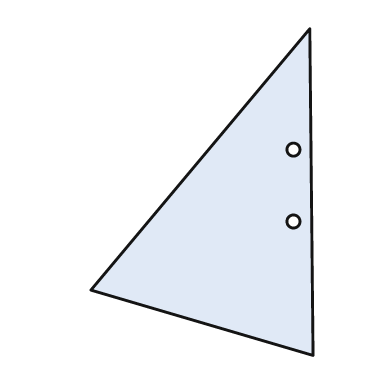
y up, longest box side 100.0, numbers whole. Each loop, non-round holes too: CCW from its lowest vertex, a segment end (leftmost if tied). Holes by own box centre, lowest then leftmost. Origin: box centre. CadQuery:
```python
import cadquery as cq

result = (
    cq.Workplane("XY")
    .moveTo(34.0, -50.0)
    .lineTo(33.0, 50.0)
    .lineTo(-34.0, -30.0)
    .close()
    .moveTo(28.0, -9.0)
    .circle(2.0)
    .moveTo(28.0, 13.0)
    .circle(2.0)
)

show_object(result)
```